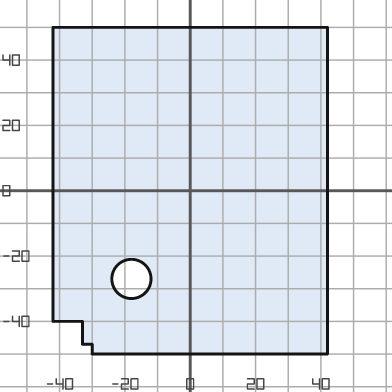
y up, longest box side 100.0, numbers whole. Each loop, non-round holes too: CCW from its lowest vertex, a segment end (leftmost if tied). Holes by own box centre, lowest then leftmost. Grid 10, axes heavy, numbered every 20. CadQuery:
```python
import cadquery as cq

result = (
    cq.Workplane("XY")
    .moveTo(-30.0, -50.0)
    .lineTo(42.0, -50.0)
    .lineTo(42.0, 50.0)
    .lineTo(-42.0, 50.0)
    .lineTo(-42.0, -40.0)
    .lineTo(-33.0, -40.0)
    .lineTo(-33.0, -47.0)
    .lineTo(-30.0, -47.0)
    .close()
    .moveTo(-18.0, -27.0)
    .circle(6.0)
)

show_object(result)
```